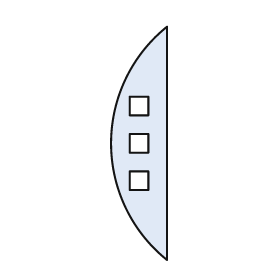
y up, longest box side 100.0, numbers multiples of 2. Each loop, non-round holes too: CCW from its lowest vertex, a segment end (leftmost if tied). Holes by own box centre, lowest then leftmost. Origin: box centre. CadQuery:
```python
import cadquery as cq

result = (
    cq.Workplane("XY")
    .moveTo(12.0, -50.0)
    .lineTo(12.0, 50.0)
    .threePointArc((-12.0, 0.0), (12.0, -50.0))
    .close()
    .moveTo(-4.0, -20.0)
    .lineTo(4.0, -20.0)
    .lineTo(4.0, -12.0)
    .lineTo(-4.0, -12.0)
    .close()
    .moveTo(-4.0, -4.0)
    .lineTo(4.0, -4.0)
    .lineTo(4.0, 4.0)
    .lineTo(-4.0, 4.0)
    .close()
    .moveTo(-4.0, 12.0)
    .lineTo(4.0, 12.0)
    .lineTo(4.0, 20.0)
    .lineTo(-4.0, 20.0)
    .close()
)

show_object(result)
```